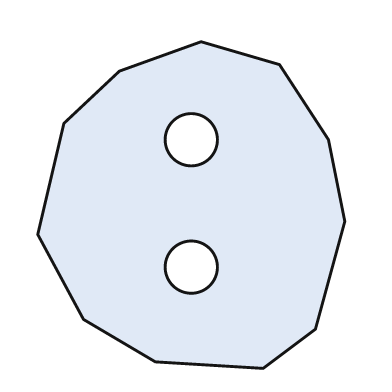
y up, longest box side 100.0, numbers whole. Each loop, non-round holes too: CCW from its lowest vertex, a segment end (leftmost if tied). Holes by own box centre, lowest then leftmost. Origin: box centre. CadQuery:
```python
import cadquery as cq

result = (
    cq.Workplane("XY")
    .moveTo(22.0, -50.0)
    .lineTo(38.0, -38.0)
    .lineTo(47.0, -5.0)
    .lineTo(42.0, 20.0)
    .lineTo(27.0, 43.0)
    .lineTo(3.0, 50.0)
    .lineTo(-22.0, 41.0)
    .lineTo(-39.0, 25.0)
    .lineTo(-47.0, -9.0)
    .lineTo(-33.0, -35.0)
    .lineTo(-11.0, -48.0)
    .close()
    .moveTo(0.0, -19.0)
    .circle(8.0)
    .moveTo(0.0, 20.0)
    .circle(8.0)
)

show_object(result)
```